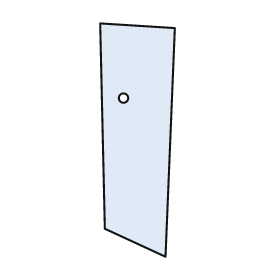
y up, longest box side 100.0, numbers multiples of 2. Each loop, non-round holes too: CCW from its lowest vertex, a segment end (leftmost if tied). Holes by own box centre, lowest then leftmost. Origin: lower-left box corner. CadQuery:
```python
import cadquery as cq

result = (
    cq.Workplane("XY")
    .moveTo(28.0, 0.0)
    .lineTo(32.0, 98.0)
    .lineTo(0.0, 100.0)
    .lineTo(2.0, 12.0)
    .close()
    .moveTo(10.0, 68.0)
    .circle(2.0)
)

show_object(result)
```